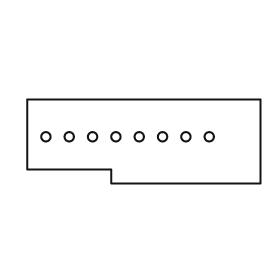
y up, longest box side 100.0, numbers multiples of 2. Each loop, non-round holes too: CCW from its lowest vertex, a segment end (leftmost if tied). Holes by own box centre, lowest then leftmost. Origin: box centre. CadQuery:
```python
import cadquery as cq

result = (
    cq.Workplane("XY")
    .moveTo(-14.0, -18.0)
    .lineTo(50.0, -18.0)
    .lineTo(50.0, 18.0)
    .lineTo(-50.0, 18.0)
    .lineTo(-50.0, -12.0)
    .lineTo(-14.0, -12.0)
    .close()
    .moveTo(-42.0, 2.0)
    .circle(2.0)
    .moveTo(-32.0, 2.0)
    .circle(2.0)
    .moveTo(-22.0, 2.0)
    .circle(2.0)
    .moveTo(-12.0, 2.0)
    .circle(2.0)
    .moveTo(-2.0, 2.0)
    .circle(2.0)
    .moveTo(8.0, 2.0)
    .circle(2.0)
    .moveTo(18.0, 2.0)
    .circle(2.0)
    .moveTo(28.0, 2.0)
    .circle(2.0)
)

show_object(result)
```